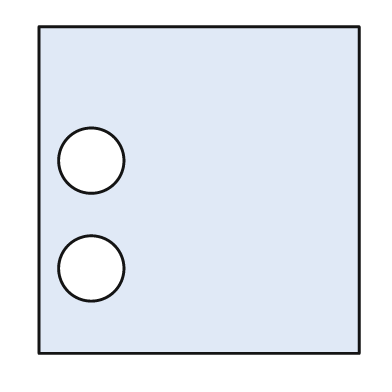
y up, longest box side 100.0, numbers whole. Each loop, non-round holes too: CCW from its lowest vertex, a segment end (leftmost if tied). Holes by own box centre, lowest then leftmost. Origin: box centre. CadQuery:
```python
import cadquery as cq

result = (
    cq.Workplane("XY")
    .moveTo(-49.0, -50.0)
    .lineTo(49.0, -50.0)
    .lineTo(49.0, 50.0)
    .lineTo(-49.0, 50.0)
    .close()
    .moveTo(-33.0, -24.0)
    .circle(10.0)
    .moveTo(-33.0, 9.0)
    .circle(10.0)
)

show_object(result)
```